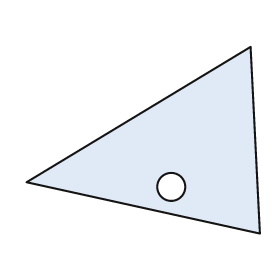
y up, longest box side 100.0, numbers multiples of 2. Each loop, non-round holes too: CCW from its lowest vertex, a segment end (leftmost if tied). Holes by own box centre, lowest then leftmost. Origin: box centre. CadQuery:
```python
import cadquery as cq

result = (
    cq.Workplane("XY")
    .moveTo(50.0, -40.0)
    .lineTo(46.0, 40.0)
    .lineTo(-50.0, -18.0)
    .close()
    .moveTo(12.0, -20.0)
    .circle(6.0)
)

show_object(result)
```